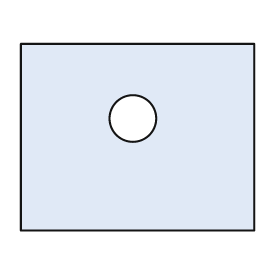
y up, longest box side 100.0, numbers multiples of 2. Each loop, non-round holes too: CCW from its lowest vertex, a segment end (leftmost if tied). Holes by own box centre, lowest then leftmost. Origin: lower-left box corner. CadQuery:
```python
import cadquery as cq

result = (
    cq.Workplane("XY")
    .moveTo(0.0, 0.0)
    .lineTo(100.0, 0.0)
    .lineTo(100.0, 80.0)
    .lineTo(0.0, 80.0)
    .close()
    .moveTo(48.0, 48.0)
    .circle(10.0)
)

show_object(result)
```